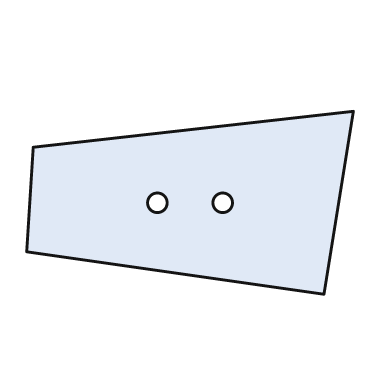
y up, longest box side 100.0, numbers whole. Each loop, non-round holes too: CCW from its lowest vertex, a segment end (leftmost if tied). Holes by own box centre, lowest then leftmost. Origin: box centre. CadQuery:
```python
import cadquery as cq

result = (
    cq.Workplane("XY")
    .moveTo(41.0, -28.0)
    .lineTo(50.0, 28.0)
    .lineTo(-48.0, 17.0)
    .lineTo(-50.0, -15.0)
    .close()
    .moveTo(-10.0, 0.0)
    .circle(3.0)
    .moveTo(10.0, 0.0)
    .circle(3.0)
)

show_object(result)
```